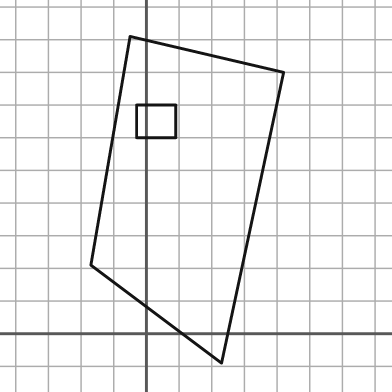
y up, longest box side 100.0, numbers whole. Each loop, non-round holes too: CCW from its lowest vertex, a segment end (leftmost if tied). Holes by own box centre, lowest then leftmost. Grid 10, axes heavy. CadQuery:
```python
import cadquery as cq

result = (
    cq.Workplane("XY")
    .moveTo(23.0, -9.0)
    .lineTo(42.0, 80.0)
    .lineTo(-5.0, 91.0)
    .lineTo(-17.0, 21.0)
    .close()
    .moveTo(-3.0, 60.0)
    .lineTo(9.0, 60.0)
    .lineTo(9.0, 70.0)
    .lineTo(-3.0, 70.0)
    .close()
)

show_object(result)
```